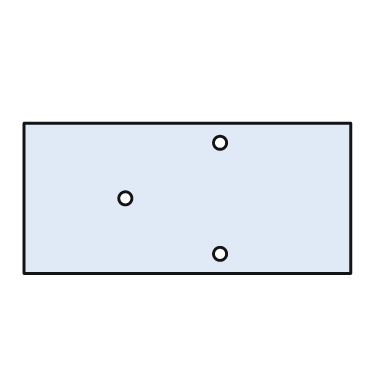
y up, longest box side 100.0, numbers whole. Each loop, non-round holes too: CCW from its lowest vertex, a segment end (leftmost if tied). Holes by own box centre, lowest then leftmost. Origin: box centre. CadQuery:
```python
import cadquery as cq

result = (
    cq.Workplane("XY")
    .moveTo(-50.0, -23.0)
    .lineTo(50.0, -23.0)
    .lineTo(50.0, 23.0)
    .lineTo(-50.0, 23.0)
    .close()
    .moveTo(10.0, -17.0)
    .circle(2.0)
    .moveTo(-19.0, 0.0)
    .circle(2.0)
    .moveTo(10.0, 17.0)
    .circle(2.0)
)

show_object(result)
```